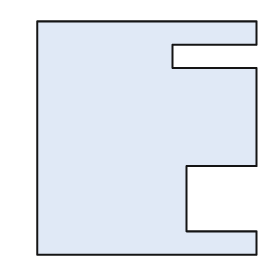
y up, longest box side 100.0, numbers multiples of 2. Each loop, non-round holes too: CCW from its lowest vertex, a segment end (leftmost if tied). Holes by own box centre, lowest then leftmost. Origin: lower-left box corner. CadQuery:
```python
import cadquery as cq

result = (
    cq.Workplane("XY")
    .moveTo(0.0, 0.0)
    .lineTo(94.0, 0.0)
    .lineTo(94.0, 10.0)
    .lineTo(64.0, 10.0)
    .lineTo(64.0, 38.0)
    .lineTo(94.0, 38.0)
    .lineTo(94.0, 80.0)
    .lineTo(58.0, 80.0)
    .lineTo(58.0, 90.0)
    .lineTo(94.0, 90.0)
    .lineTo(94.0, 100.0)
    .lineTo(0.0, 100.0)
    .close()
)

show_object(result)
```